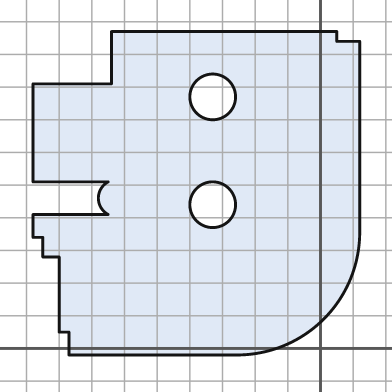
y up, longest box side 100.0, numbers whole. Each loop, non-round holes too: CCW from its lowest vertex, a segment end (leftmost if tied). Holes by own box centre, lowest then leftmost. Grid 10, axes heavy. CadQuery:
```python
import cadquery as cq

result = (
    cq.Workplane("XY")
    .moveTo(-77.0, -2.0)
    .lineTo(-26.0, -2.0)
    .threePointArc((1.0, 9.0), (12.0, 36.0))
    .lineTo(12.0, 94.0)
    .lineTo(5.0, 94.0)
    .lineTo(5.0, 97.0)
    .lineTo(-64.0, 97.0)
    .lineTo(-64.0, 81.0)
    .lineTo(-88.0, 81.0)
    .lineTo(-88.0, 51.0)
    .lineTo(-65.0, 51.0)
    .threePointArc((-68.0, 46.0), (-65.0, 41.0))
    .lineTo(-88.0, 41.0)
    .lineTo(-88.0, 34.0)
    .lineTo(-85.0, 34.0)
    .lineTo(-85.0, 28.0)
    .lineTo(-80.0, 28.0)
    .lineTo(-80.0, 5.0)
    .lineTo(-77.0, 5.0)
    .close()
    .moveTo(-33.0, 44.0)
    .circle(7.0)
    .moveTo(-33.0, 77.0)
    .circle(7.0)
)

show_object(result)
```